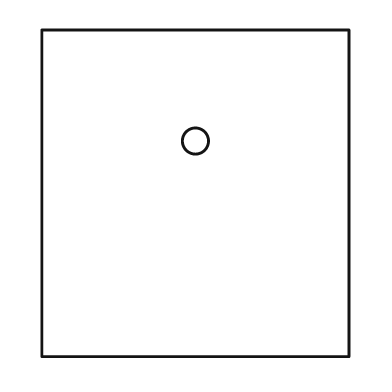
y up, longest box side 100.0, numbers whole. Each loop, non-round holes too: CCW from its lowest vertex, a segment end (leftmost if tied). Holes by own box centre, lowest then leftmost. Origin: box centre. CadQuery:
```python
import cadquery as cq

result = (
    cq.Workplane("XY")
    .moveTo(-47.0, -50.0)
    .lineTo(47.0, -50.0)
    .lineTo(47.0, 50.0)
    .lineTo(-47.0, 50.0)
    .close()
    .moveTo(0.0, 16.0)
    .circle(4.0)
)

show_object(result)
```